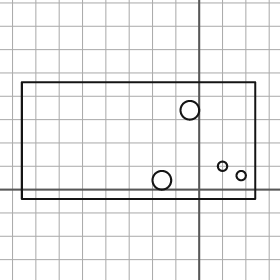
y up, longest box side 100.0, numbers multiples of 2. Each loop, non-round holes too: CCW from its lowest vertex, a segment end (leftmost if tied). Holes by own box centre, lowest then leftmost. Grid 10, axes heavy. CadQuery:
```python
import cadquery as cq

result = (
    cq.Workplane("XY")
    .moveTo(-76.0, -4.0)
    .lineTo(24.0, -4.0)
    .lineTo(24.0, 46.0)
    .lineTo(-76.0, 46.0)
    .close()
    .moveTo(-16.0, 4.0)
    .circle(4.0)
    .moveTo(18.0, 6.0)
    .circle(2.0)
    .moveTo(10.0, 10.0)
    .circle(2.0)
    .moveTo(-4.0, 34.0)
    .circle(4.0)
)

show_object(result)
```